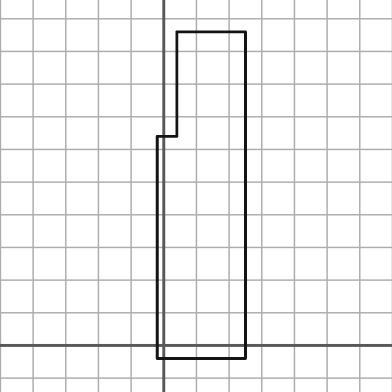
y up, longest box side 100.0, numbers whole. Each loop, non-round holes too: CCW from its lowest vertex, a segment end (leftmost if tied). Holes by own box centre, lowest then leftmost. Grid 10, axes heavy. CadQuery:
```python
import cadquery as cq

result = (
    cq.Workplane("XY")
    .moveTo(-2.0, -4.0)
    .lineTo(25.0, -4.0)
    .lineTo(25.0, 96.0)
    .lineTo(4.0, 96.0)
    .lineTo(4.0, 64.0)
    .lineTo(-2.0, 64.0)
    .close()
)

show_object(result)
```